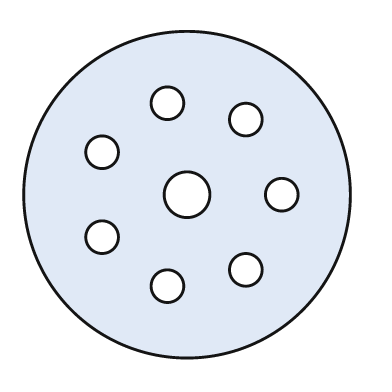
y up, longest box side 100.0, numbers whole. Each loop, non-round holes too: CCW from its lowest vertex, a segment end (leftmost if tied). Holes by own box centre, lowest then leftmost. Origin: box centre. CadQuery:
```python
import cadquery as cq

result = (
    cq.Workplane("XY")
    .moveTo(0.0, 0.0)
    .circle(50.0)
    .moveTo(-6.0, -28.0)
    .circle(5.0)
    .moveTo(18.0, -23.0)
    .circle(5.0)
    .moveTo(-26.0, -13.0)
    .circle(5.0)
    .moveTo(0.0, 0.0)
    .circle(7.0)
    .moveTo(29.0, 0.0)
    .circle(5.0)
    .moveTo(-26.0, 13.0)
    .circle(5.0)
    .moveTo(18.0, 23.0)
    .circle(5.0)
    .moveTo(-6.0, 28.0)
    .circle(5.0)
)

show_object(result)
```